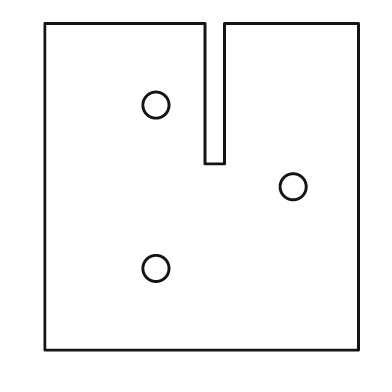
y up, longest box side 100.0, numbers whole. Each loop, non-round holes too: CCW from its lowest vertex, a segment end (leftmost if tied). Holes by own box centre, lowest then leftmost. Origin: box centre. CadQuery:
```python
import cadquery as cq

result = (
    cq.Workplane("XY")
    .moveTo(-48.0, -50.0)
    .lineTo(48.0, -50.0)
    .lineTo(48.0, 50.0)
    .lineTo(7.0, 50.0)
    .lineTo(7.0, 7.0)
    .lineTo(1.0, 7.0)
    .lineTo(1.0, 50.0)
    .lineTo(-48.0, 50.0)
    .close()
    .moveTo(-14.0, -25.0)
    .circle(4.0)
    .moveTo(28.0, 0.0)
    .circle(4.0)
    .moveTo(-14.0, 25.0)
    .circle(4.0)
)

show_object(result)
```